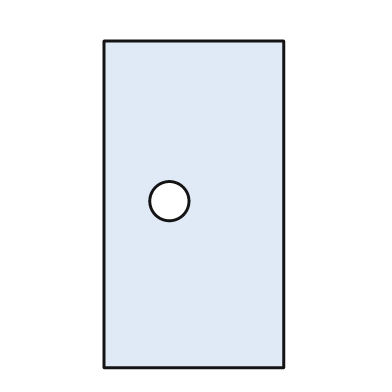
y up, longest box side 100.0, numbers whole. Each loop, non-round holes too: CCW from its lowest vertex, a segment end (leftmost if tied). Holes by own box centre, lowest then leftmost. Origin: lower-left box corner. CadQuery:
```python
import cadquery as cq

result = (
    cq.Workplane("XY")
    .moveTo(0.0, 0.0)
    .lineTo(55.0, 0.0)
    .lineTo(55.0, 100.0)
    .lineTo(0.0, 100.0)
    .close()
    .moveTo(20.0, 51.0)
    .circle(6.0)
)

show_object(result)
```